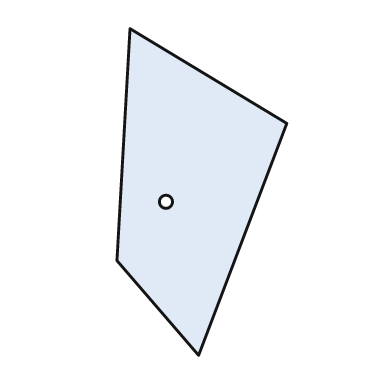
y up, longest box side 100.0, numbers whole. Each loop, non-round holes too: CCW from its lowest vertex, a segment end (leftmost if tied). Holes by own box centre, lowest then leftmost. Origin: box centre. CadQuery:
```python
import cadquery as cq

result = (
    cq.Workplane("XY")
    .moveTo(-1.0, -50.0)
    .lineTo(26.0, 21.0)
    .lineTo(-22.0, 50.0)
    .lineTo(-26.0, -21.0)
    .close()
    .moveTo(-11.0, -3.0)
    .circle(2.0)
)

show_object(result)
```